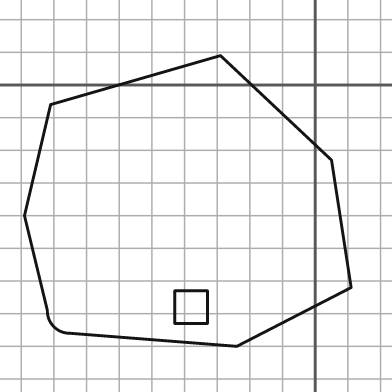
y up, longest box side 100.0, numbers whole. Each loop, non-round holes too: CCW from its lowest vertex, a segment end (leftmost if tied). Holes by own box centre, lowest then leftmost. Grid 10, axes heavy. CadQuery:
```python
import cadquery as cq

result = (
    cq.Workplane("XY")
    .moveTo(-24.0, -80.0)
    .lineTo(11.0, -62.0)
    .lineTo(5.0, -23.0)
    .lineTo(-29.0, 9.0)
    .lineTo(-81.0, -6.0)
    .lineTo(-89.0, -40.0)
    .lineTo(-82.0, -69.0)
    .threePointArc((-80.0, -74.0), (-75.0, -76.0))
    .close()
    .moveTo(-43.0, -73.0)
    .lineTo(-33.0, -73.0)
    .lineTo(-33.0, -63.0)
    .lineTo(-43.0, -63.0)
    .close()
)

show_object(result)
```